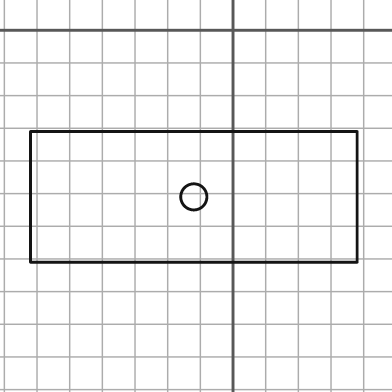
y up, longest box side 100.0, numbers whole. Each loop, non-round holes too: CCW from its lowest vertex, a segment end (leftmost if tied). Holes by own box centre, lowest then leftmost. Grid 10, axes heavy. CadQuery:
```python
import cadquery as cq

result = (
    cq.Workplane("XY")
    .moveTo(-62.0, -71.0)
    .lineTo(38.0, -71.0)
    .lineTo(38.0, -31.0)
    .lineTo(-62.0, -31.0)
    .close()
    .moveTo(-12.0, -51.0)
    .circle(4.0)
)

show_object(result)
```